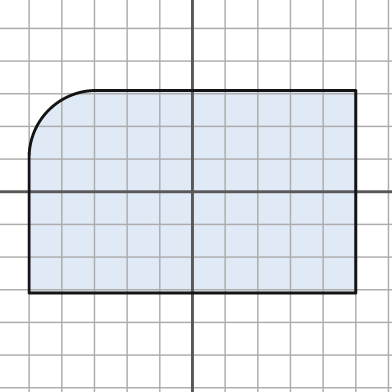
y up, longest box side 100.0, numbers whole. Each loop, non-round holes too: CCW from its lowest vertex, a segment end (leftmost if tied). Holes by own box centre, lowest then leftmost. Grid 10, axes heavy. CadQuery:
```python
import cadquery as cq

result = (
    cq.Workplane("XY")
    .moveTo(-50.0, -31.0)
    .lineTo(50.0, -31.0)
    .lineTo(50.0, 31.0)
    .lineTo(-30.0, 31.0)
    .threePointArc((-44.0, 25.0), (-50.0, 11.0))
    .close()
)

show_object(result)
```